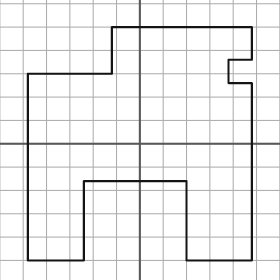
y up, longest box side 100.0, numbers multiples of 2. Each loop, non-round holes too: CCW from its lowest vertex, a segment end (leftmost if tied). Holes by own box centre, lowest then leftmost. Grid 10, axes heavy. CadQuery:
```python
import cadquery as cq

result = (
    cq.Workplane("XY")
    .moveTo(-48.0, -50.0)
    .lineTo(-24.0, -50.0)
    .lineTo(-24.0, -16.0)
    .lineTo(20.0, -16.0)
    .lineTo(20.0, -50.0)
    .lineTo(48.0, -50.0)
    .lineTo(48.0, 26.0)
    .lineTo(38.0, 26.0)
    .lineTo(38.0, 36.0)
    .lineTo(48.0, 36.0)
    .lineTo(48.0, 50.0)
    .lineTo(-12.0, 50.0)
    .lineTo(-12.0, 30.0)
    .lineTo(-48.0, 30.0)
    .close()
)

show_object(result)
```